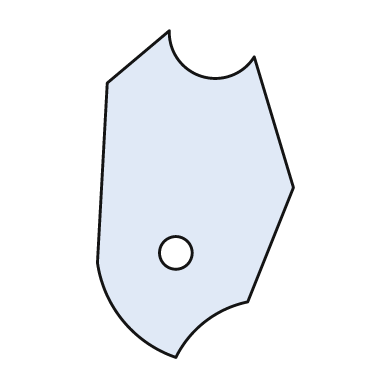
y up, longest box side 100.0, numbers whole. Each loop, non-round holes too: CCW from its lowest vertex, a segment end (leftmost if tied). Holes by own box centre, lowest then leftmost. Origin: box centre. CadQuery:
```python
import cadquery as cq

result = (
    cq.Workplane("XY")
    .moveTo(-6.0, -50.0)
    .threePointArc((3.0, -39.0), (16.0, -33.0))
    .lineTo(30.0, 2.0)
    .lineTo(18.0, 42.0)
    .threePointArc((2.0, 36.0), (-8.0, 50.0))
    .lineTo(-27.0, 34.0)
    .lineTo(-30.0, -21.0)
    .threePointArc((-22.0, -39.0), (-6.0, -50.0))
    .close()
    .moveTo(-6.0, -18.0)
    .circle(5.0)
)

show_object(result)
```